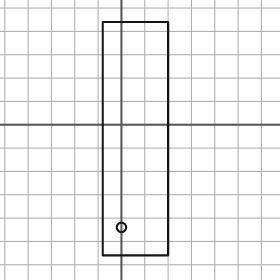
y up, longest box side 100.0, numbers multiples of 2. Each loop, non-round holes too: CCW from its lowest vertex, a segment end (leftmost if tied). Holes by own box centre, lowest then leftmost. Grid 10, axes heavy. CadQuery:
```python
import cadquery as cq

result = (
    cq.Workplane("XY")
    .moveTo(-8.0, -56.0)
    .lineTo(20.0, -56.0)
    .lineTo(20.0, 44.0)
    .lineTo(-8.0, 44.0)
    .close()
    .moveTo(0.0, -44.0)
    .circle(2.0)
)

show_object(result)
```